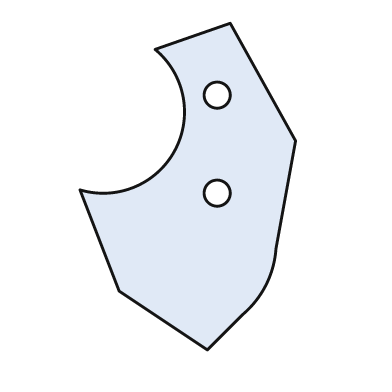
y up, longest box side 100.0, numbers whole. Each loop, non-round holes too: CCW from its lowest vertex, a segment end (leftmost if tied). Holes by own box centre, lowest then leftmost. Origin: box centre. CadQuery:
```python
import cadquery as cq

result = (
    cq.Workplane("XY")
    .moveTo(6.0, -50.0)
    .lineTo(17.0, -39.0)
    .threePointArc((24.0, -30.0), (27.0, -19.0))
    .lineTo(33.0, 14.0)
    .lineTo(13.0, 50.0)
    .lineTo(-10.0, 42.0)
    .threePointArc((-4.0, 11.0), (-33.0, -1.0))
    .lineTo(-21.0, -32.0)
    .close()
    .moveTo(9.0, -2.0)
    .circle(4.0)
    .moveTo(9.0, 28.0)
    .circle(4.0)
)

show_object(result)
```